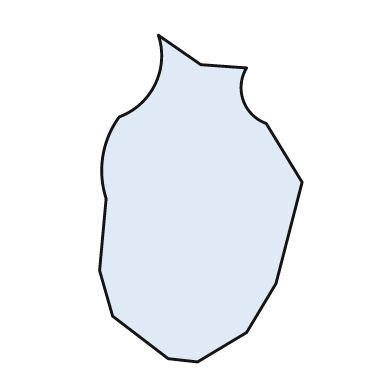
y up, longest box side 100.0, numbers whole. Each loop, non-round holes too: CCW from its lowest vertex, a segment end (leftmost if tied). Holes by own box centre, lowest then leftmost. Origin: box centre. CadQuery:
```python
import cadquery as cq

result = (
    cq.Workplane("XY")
    .moveTo(-1.0, -50.0)
    .lineTo(14.0, -41.0)
    .lineTo(23.0, -26.0)
    .lineTo(31.0, 5.0)
    .lineTo(20.0, 23.0)
    .threePointArc((13.0, 30.0), (14.0, 40.0))
    .lineTo(0.0, 41.0)
    .lineTo(-13.0, 50.0)
    .threePointArc((-14.0, 35.0), (-25.0, 25.0))
    .threePointArc((-30.0, 13.0), (-29.0, 0.0))
    .lineTo(-31.0, -22.0)
    .lineTo(-27.0, -36.0)
    .lineTo(-10.0, -49.0)
    .close()
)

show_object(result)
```